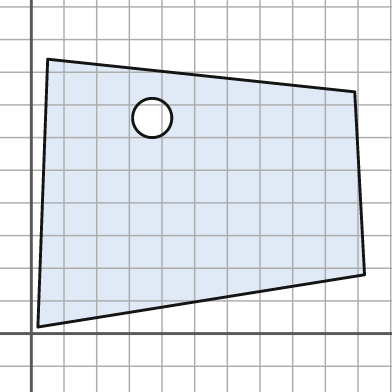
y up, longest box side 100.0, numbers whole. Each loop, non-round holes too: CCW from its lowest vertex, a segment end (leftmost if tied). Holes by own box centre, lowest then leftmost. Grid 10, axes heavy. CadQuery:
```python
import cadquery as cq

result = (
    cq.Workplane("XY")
    .moveTo(2.0, 2.0)
    .lineTo(102.0, 18.0)
    .lineTo(99.0, 74.0)
    .lineTo(5.0, 84.0)
    .close()
    .moveTo(37.0, 66.0)
    .circle(6.0)
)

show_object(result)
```